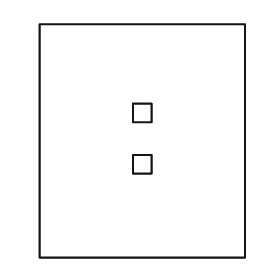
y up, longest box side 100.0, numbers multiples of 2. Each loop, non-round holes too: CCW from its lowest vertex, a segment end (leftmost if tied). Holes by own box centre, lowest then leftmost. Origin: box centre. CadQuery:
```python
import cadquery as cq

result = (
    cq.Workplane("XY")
    .moveTo(-44.0, -50.0)
    .lineTo(44.0, -50.0)
    .lineTo(44.0, 50.0)
    .lineTo(-44.0, 50.0)
    .close()
    .moveTo(-4.0, -14.0)
    .lineTo(4.0, -14.0)
    .lineTo(4.0, -6.0)
    .lineTo(-4.0, -6.0)
    .close()
    .moveTo(-4.0, 8.0)
    .lineTo(4.0, 8.0)
    .lineTo(4.0, 16.0)
    .lineTo(-4.0, 16.0)
    .close()
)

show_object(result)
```